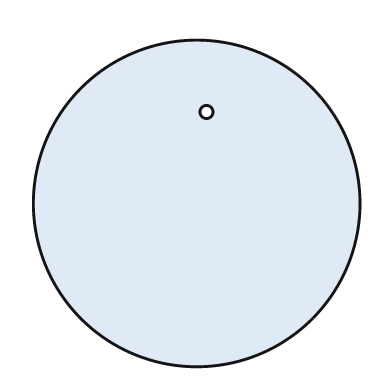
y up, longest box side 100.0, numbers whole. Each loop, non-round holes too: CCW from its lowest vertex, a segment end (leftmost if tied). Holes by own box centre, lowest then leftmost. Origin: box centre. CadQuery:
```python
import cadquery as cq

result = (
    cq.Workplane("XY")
    .moveTo(0.0, 0.0)
    .circle(50.0)
    .moveTo(3.0, 28.0)
    .circle(2.0)
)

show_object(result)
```